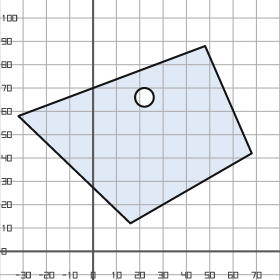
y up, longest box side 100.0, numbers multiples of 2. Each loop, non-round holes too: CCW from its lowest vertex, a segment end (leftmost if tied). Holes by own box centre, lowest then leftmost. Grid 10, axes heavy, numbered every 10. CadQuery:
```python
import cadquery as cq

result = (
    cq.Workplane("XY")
    .moveTo(16.0, 12.0)
    .lineTo(68.0, 42.0)
    .lineTo(48.0, 88.0)
    .lineTo(-32.0, 58.0)
    .close()
    .moveTo(22.0, 66.0)
    .circle(4.0)
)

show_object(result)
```